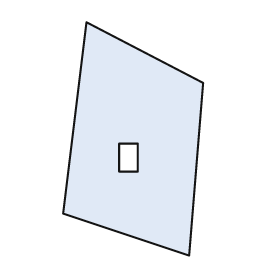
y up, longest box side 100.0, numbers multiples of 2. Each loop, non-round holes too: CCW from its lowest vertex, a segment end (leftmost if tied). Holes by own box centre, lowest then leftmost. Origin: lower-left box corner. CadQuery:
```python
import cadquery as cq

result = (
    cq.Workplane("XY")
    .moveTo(54.0, 0.0)
    .lineTo(60.0, 74.0)
    .lineTo(10.0, 100.0)
    .lineTo(0.0, 18.0)
    .close()
    .moveTo(24.0, 36.0)
    .lineTo(32.0, 36.0)
    .lineTo(32.0, 48.0)
    .lineTo(24.0, 48.0)
    .close()
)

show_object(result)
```